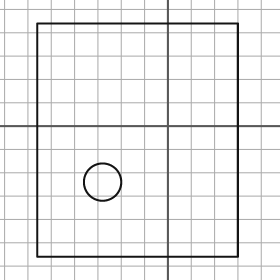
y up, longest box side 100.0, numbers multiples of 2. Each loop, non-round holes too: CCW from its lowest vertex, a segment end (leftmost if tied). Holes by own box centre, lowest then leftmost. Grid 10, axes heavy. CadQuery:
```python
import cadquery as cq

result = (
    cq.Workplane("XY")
    .moveTo(-56.0, -56.0)
    .lineTo(30.0, -56.0)
    .lineTo(30.0, 44.0)
    .lineTo(-56.0, 44.0)
    .close()
    .moveTo(-28.0, -24.0)
    .circle(8.0)
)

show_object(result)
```